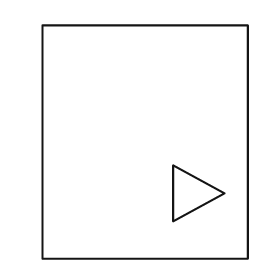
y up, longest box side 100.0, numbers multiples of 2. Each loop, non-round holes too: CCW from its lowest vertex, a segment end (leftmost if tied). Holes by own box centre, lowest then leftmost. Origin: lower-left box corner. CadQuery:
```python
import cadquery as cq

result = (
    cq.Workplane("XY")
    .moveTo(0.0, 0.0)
    .lineTo(88.0, 0.0)
    .lineTo(88.0, 100.0)
    .lineTo(0.0, 100.0)
    .close()
    .moveTo(56.0, 16.0)
    .lineTo(78.0, 28.0)
    .lineTo(56.0, 40.0)
    .close()
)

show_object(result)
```